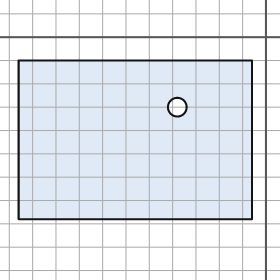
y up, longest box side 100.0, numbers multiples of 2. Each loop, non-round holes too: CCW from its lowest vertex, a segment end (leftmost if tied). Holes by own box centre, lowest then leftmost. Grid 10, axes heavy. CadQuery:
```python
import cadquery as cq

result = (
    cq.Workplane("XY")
    .moveTo(-106.0, -78.0)
    .lineTo(-6.0, -78.0)
    .lineTo(-6.0, -10.0)
    .lineTo(-106.0, -10.0)
    .close()
    .moveTo(-38.0, -30.0)
    .circle(4.0)
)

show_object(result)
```